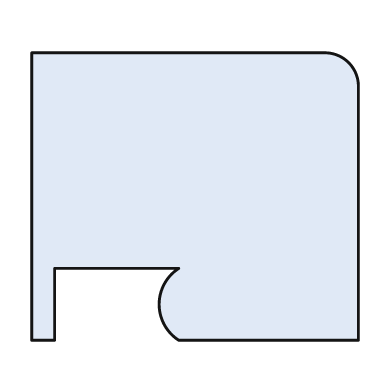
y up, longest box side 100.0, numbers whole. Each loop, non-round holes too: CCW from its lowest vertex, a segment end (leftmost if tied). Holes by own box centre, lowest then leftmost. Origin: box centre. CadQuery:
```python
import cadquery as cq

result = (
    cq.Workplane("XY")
    .moveTo(-50.0, -44.0)
    .lineTo(-43.0, -44.0)
    .lineTo(-43.0, -22.0)
    .lineTo(-5.0, -22.0)
    .threePointArc((-11.0, -33.0), (-5.0, -44.0))
    .lineTo(50.0, -44.0)
    .lineTo(50.0, 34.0)
    .threePointArc((47.0, 41.0), (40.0, 44.0))
    .lineTo(-50.0, 44.0)
    .close()
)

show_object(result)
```